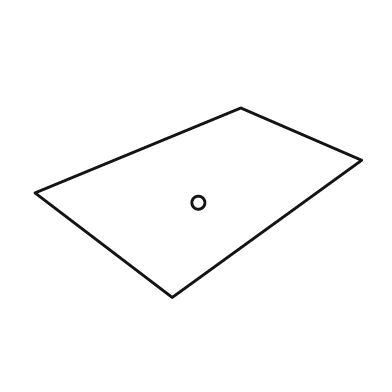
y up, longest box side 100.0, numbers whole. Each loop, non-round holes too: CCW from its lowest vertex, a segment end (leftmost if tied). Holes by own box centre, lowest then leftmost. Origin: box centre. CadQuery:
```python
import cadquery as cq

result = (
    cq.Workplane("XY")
    .moveTo(-8.0, -29.0)
    .lineTo(50.0, 13.0)
    .lineTo(13.0, 29.0)
    .lineTo(-50.0, 3.0)
    .close()
    .moveTo(0.0, 0.0)
    .circle(2.0)
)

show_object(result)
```